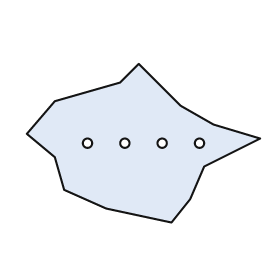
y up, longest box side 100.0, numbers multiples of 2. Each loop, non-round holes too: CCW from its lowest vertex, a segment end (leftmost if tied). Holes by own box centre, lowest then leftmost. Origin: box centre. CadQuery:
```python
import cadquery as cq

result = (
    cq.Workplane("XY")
    .moveTo(12.0, -34.0)
    .lineTo(20.0, -24.0)
    .lineTo(26.0, -10.0)
    .lineTo(50.0, 2.0)
    .lineTo(30.0, 8.0)
    .lineTo(16.0, 16.0)
    .lineTo(-2.0, 34.0)
    .lineTo(-10.0, 26.0)
    .lineTo(-38.0, 18.0)
    .lineTo(-50.0, 4.0)
    .lineTo(-38.0, -6.0)
    .lineTo(-34.0, -20.0)
    .lineTo(-16.0, -28.0)
    .close()
    .moveTo(-24.0, 0.0)
    .circle(2.0)
    .moveTo(-8.0, 0.0)
    .circle(2.0)
    .moveTo(8.0, 0.0)
    .circle(2.0)
    .moveTo(24.0, 0.0)
    .circle(2.0)
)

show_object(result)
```